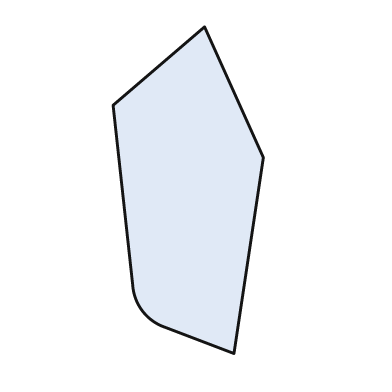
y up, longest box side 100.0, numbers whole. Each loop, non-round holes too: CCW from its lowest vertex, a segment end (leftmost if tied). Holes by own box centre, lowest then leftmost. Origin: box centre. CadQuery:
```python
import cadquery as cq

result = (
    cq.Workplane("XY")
    .moveTo(14.0, -50.0)
    .lineTo(23.0, 10.0)
    .lineTo(5.0, 50.0)
    .lineTo(-23.0, 26.0)
    .lineTo(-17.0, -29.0)
    .threePointArc((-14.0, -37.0), (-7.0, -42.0))
    .close()
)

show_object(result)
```